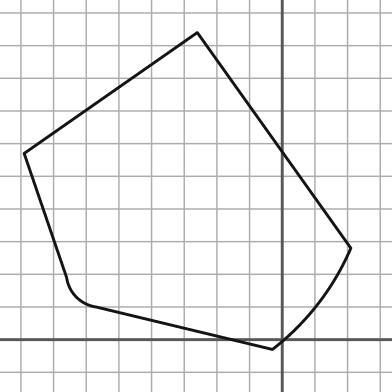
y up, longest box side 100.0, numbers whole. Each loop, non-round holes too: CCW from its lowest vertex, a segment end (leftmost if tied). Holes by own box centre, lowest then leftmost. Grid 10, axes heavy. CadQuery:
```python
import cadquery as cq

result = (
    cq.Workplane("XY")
    .moveTo(-3.0, -3.0)
    .threePointArc((11.0, 11.0), (21.0, 28.0))
    .lineTo(-26.0, 94.0)
    .lineTo(-79.0, 57.0)
    .lineTo(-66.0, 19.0)
    .threePointArc((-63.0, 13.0), (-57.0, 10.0))
    .close()
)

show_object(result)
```